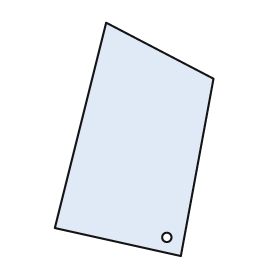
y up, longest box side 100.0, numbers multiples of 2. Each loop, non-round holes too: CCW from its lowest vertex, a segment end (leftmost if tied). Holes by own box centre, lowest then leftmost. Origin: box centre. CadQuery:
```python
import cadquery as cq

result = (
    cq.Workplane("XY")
    .moveTo(20.0, -50.0)
    .lineTo(34.0, 26.0)
    .lineTo(-12.0, 50.0)
    .lineTo(-34.0, -38.0)
    .close()
    .moveTo(14.0, -42.0)
    .circle(2.0)
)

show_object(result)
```